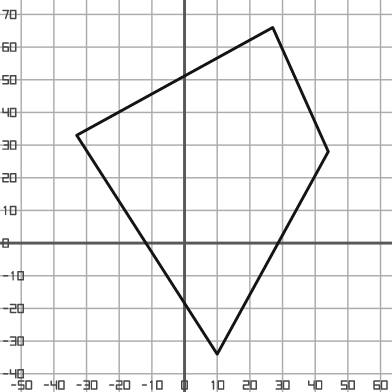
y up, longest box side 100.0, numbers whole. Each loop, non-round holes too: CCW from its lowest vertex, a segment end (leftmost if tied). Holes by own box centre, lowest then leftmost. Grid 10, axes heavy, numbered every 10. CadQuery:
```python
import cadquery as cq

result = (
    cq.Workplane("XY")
    .moveTo(10.0, -34.0)
    .lineTo(44.0, 28.0)
    .lineTo(27.0, 66.0)
    .lineTo(-33.0, 33.0)
    .close()
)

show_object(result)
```